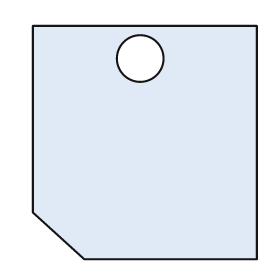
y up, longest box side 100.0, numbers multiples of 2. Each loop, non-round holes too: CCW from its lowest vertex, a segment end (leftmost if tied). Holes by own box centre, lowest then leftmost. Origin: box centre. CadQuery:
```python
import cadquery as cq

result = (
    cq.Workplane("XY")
    .moveTo(-26.0, -50.0)
    .lineTo(48.0, -50.0)
    .lineTo(48.0, 50.0)
    .lineTo(-48.0, 50.0)
    .lineTo(-48.0, -30.0)
    .close()
    .moveTo(-2.0, 36.0)
    .circle(10.0)
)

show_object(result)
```